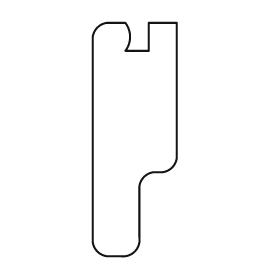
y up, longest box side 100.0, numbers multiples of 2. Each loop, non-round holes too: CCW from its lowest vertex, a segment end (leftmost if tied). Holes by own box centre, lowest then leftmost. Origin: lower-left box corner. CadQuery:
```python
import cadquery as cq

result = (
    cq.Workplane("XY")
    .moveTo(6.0, 0.0)
    .lineTo(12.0, 0.0)
    .threePointArc((18.0, 2.0), (20.0, 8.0))
    .lineTo(20.0, 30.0)
    .threePointArc((22.0, 34.0), (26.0, 36.0))
    .lineTo(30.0, 36.0)
    .threePointArc((34.0, 38.0), (36.0, 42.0))
    .lineTo(36.0, 100.0)
    .lineTo(24.0, 100.0)
    .lineTo(24.0, 88.0)
    .lineTo(14.0, 88.0)
    .threePointArc((16.0, 94.0), (14.0, 100.0))
    .lineTo(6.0, 100.0)
    .threePointArc((2.0, 98.0), (0.0, 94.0))
    .lineTo(0.0, 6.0)
    .threePointArc((2.0, 2.0), (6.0, 0.0))
    .close()
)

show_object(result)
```